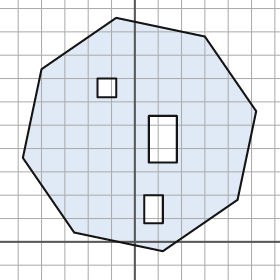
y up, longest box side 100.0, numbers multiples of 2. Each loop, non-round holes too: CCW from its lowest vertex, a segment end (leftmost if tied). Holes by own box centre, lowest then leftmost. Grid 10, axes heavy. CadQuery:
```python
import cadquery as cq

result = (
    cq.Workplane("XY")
    .moveTo(12.0, -4.0)
    .lineTo(44.0, 18.0)
    .lineTo(52.0, 56.0)
    .lineTo(30.0, 88.0)
    .lineTo(-8.0, 96.0)
    .lineTo(-40.0, 74.0)
    .lineTo(-48.0, 36.0)
    .lineTo(-26.0, 4.0)
    .close()
    .moveTo(4.0, 8.0)
    .lineTo(12.0, 8.0)
    .lineTo(12.0, 20.0)
    .lineTo(4.0, 20.0)
    .close()
    .moveTo(6.0, 34.0)
    .lineTo(18.0, 34.0)
    .lineTo(18.0, 54.0)
    .lineTo(6.0, 54.0)
    .close()
    .moveTo(-16.0, 62.0)
    .lineTo(-8.0, 62.0)
    .lineTo(-8.0, 70.0)
    .lineTo(-16.0, 70.0)
    .close()
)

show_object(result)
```